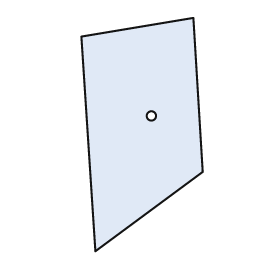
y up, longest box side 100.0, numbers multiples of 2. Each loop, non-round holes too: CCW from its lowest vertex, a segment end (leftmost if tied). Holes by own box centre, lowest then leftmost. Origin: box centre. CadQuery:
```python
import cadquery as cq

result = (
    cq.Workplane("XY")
    .moveTo(-20.0, -50.0)
    .lineTo(26.0, -16.0)
    .lineTo(22.0, 50.0)
    .lineTo(-26.0, 42.0)
    .close()
    .moveTo(4.0, 8.0)
    .circle(2.0)
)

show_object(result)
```